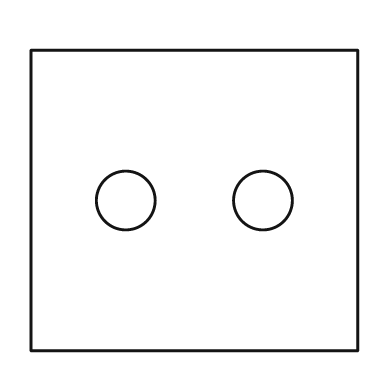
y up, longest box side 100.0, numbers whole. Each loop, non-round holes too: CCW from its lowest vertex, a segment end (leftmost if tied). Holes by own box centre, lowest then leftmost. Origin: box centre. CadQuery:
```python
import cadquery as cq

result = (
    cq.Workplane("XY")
    .moveTo(-50.0, -46.0)
    .lineTo(50.0, -46.0)
    .lineTo(50.0, 46.0)
    .lineTo(-50.0, 46.0)
    .close()
    .moveTo(-21.0, 0.0)
    .circle(9.0)
    .moveTo(21.0, 0.0)
    .circle(9.0)
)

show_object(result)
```